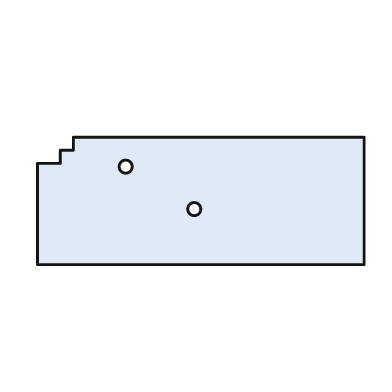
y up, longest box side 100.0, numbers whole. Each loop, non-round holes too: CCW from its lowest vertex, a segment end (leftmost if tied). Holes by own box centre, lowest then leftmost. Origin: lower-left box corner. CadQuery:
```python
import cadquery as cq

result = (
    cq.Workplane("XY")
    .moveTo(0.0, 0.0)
    .lineTo(100.0, 0.0)
    .lineTo(100.0, 39.0)
    .lineTo(11.0, 39.0)
    .lineTo(11.0, 35.0)
    .lineTo(7.0, 35.0)
    .lineTo(7.0, 31.0)
    .lineTo(0.0, 31.0)
    .close()
    .moveTo(48.0, 17.0)
    .circle(2.0)
    .moveTo(27.0, 30.0)
    .circle(2.0)
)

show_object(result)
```